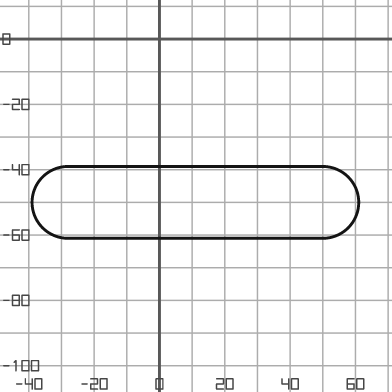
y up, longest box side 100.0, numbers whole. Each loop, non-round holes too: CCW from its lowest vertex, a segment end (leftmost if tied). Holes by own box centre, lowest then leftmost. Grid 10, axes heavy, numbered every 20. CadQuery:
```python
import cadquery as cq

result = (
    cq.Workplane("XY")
    .moveTo(-28.0, -61.0)
    .lineTo(50.0, -61.0)
    .threePointArc((61.0, -50.0), (50.0, -39.0))
    .lineTo(-28.0, -39.0)
    .threePointArc((-39.0, -50.0), (-28.0, -61.0))
    .close()
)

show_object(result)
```